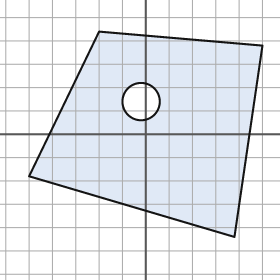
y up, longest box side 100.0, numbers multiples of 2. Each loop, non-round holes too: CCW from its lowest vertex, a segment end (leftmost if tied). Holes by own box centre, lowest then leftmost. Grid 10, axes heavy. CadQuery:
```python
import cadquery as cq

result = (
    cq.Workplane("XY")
    .moveTo(38.0, -44.0)
    .lineTo(50.0, 38.0)
    .lineTo(-20.0, 44.0)
    .lineTo(-50.0, -18.0)
    .close()
    .moveTo(-2.0, 14.0)
    .circle(8.0)
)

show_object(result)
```